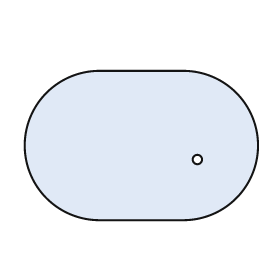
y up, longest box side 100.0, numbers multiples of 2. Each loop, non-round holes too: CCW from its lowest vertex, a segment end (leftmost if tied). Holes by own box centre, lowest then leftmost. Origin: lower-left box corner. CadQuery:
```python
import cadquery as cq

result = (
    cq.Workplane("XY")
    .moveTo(32.0, 0.0)
    .lineTo(68.0, 0.0)
    .threePointArc((100.0, 32.0), (68.0, 64.0))
    .lineTo(32.0, 64.0)
    .threePointArc((0.0, 32.0), (32.0, 0.0))
    .close()
    .moveTo(74.0, 26.0)
    .circle(2.0)
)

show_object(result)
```